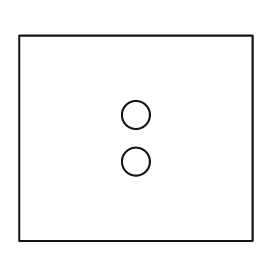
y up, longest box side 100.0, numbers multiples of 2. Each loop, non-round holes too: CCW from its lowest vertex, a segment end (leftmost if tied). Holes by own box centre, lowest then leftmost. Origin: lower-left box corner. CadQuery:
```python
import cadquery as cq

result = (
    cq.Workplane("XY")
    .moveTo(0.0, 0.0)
    .lineTo(100.0, 0.0)
    .lineTo(100.0, 88.0)
    .lineTo(0.0, 88.0)
    .close()
    .moveTo(50.0, 34.0)
    .circle(6.0)
    .moveTo(50.0, 54.0)
    .circle(6.0)
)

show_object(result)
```